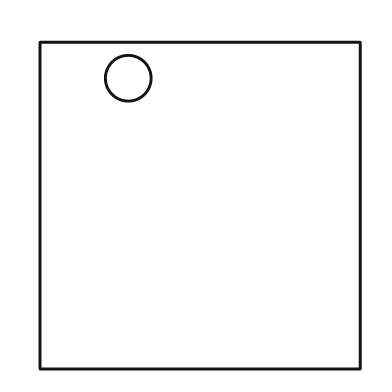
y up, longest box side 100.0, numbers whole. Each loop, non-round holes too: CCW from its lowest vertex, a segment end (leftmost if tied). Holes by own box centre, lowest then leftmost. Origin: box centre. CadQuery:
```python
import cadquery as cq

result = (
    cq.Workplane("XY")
    .moveTo(-49.0, -50.0)
    .lineTo(49.0, -50.0)
    .lineTo(49.0, 50.0)
    .lineTo(-49.0, 50.0)
    .close()
    .moveTo(-22.0, 39.0)
    .circle(7.0)
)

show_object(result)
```